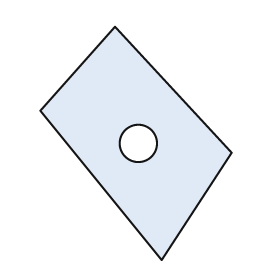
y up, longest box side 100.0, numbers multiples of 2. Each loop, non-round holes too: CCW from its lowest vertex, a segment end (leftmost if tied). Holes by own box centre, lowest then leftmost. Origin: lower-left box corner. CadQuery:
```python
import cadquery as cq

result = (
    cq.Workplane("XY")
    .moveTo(52.0, 0.0)
    .lineTo(82.0, 46.0)
    .lineTo(32.0, 100.0)
    .lineTo(0.0, 64.0)
    .close()
    .moveTo(42.0, 50.0)
    .circle(8.0)
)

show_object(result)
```